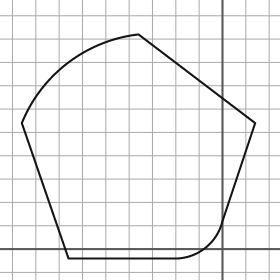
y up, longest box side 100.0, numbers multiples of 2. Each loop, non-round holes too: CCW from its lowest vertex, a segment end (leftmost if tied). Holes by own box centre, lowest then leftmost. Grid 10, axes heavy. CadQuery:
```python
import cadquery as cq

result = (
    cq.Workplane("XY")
    .moveTo(-66.0, -4.0)
    .lineTo(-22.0, -4.0)
    .threePointArc((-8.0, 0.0), (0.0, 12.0))
    .lineTo(14.0, 54.0)
    .lineTo(-36.0, 92.0)
    .threePointArc((-66.0, 80.0), (-86.0, 54.0))
    .close()
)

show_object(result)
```